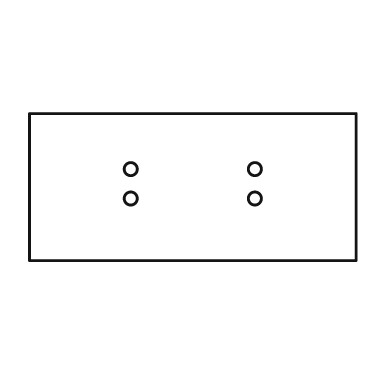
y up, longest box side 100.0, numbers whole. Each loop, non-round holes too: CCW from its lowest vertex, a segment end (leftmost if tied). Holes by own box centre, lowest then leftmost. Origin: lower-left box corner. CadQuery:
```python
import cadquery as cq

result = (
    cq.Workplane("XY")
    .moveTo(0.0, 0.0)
    .lineTo(100.0, 0.0)
    .lineTo(100.0, 45.0)
    .lineTo(0.0, 45.0)
    .close()
    .moveTo(31.0, 19.0)
    .circle(2.0)
    .moveTo(69.0, 19.0)
    .circle(2.0)
    .moveTo(31.0, 28.0)
    .circle(2.0)
    .moveTo(69.0, 28.0)
    .circle(2.0)
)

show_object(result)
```